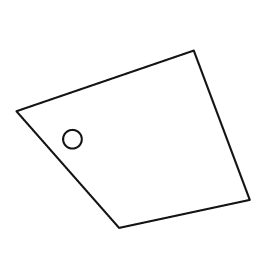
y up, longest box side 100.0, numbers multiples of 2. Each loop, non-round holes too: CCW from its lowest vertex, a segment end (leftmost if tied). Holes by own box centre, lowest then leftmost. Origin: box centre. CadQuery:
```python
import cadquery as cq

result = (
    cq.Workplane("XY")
    .moveTo(-6.0, -38.0)
    .lineTo(50.0, -26.0)
    .lineTo(26.0, 38.0)
    .lineTo(-50.0, 12.0)
    .close()
    .moveTo(-26.0, 0.0)
    .circle(4.0)
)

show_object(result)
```